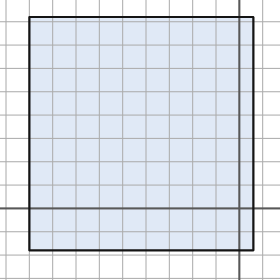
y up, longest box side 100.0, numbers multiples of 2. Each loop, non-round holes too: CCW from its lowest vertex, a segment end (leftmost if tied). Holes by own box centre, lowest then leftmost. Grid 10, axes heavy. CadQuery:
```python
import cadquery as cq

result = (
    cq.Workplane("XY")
    .moveTo(-90.0, -18.0)
    .lineTo(6.0, -18.0)
    .lineTo(6.0, 82.0)
    .lineTo(-90.0, 82.0)
    .close()
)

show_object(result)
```